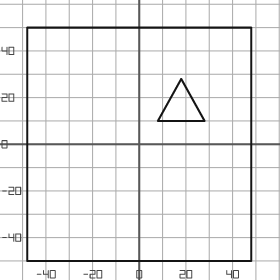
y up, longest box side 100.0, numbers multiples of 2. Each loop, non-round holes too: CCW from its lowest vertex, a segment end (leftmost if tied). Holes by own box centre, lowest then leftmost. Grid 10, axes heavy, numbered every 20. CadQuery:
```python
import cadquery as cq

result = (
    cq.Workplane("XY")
    .moveTo(-48.0, -50.0)
    .lineTo(48.0, -50.0)
    .lineTo(48.0, 50.0)
    .lineTo(-48.0, 50.0)
    .close()
    .moveTo(8.0, 10.0)
    .lineTo(28.0, 10.0)
    .lineTo(18.0, 28.0)
    .close()
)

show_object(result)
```